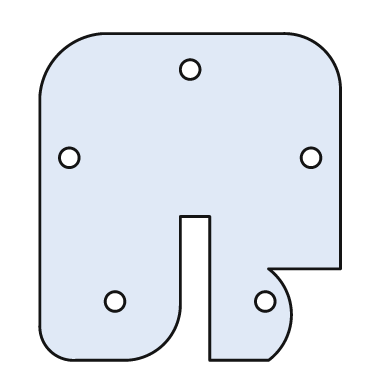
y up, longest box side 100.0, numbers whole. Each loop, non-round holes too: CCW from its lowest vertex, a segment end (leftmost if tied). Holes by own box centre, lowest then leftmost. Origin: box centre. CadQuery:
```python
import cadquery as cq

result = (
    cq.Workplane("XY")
    .moveTo(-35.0, -50.0)
    .lineTo(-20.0, -50.0)
    .threePointArc((-8.0, -45.0), (-3.0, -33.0))
    .lineTo(-3.0, -6.0)
    .lineTo(6.0, -6.0)
    .lineTo(6.0, -50.0)
    .lineTo(24.0, -50.0)
    .threePointArc((31.0, -36.0), (24.0, -22.0))
    .lineTo(46.0, -22.0)
    .lineTo(46.0, 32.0)
    .threePointArc((41.0, 45.0), (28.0, 50.0))
    .lineTo(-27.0, 50.0)
    .threePointArc((-40.0, 44.0), (-46.0, 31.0))
    .lineTo(-46.0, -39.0)
    .threePointArc((-43.0, -47.0), (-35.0, -50.0))
    .close()
    .moveTo(-23.0, -32.0)
    .circle(3.0)
    .moveTo(23.0, -32.0)
    .circle(3.0)
    .moveTo(-37.0, 12.0)
    .circle(3.0)
    .moveTo(37.0, 12.0)
    .circle(3.0)
    .moveTo(0.0, 39.0)
    .circle(3.0)
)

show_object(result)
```